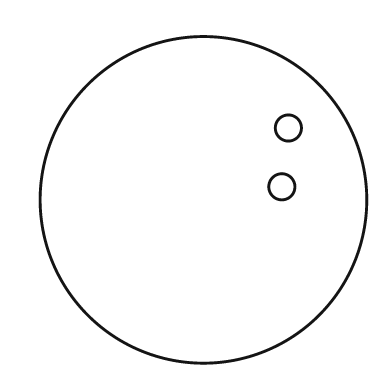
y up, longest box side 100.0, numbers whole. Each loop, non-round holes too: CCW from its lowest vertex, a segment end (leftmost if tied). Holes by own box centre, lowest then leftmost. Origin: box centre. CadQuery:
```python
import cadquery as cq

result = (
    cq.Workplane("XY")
    .moveTo(0.0, 0.0)
    .circle(50.0)
    .moveTo(24.0, 4.0)
    .circle(4.0)
    .moveTo(26.0, 22.0)
    .circle(4.0)
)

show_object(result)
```